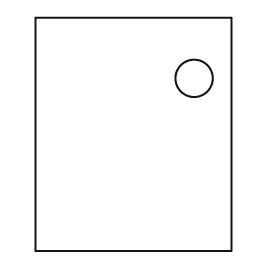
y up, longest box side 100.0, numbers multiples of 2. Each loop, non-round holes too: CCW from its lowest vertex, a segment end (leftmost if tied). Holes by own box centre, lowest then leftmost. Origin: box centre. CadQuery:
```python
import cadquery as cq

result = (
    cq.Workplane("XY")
    .moveTo(-42.0, -50.0)
    .lineTo(42.0, -50.0)
    .lineTo(42.0, 50.0)
    .lineTo(-42.0, 50.0)
    .close()
    .moveTo(26.0, 24.0)
    .circle(8.0)
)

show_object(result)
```